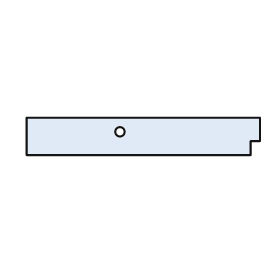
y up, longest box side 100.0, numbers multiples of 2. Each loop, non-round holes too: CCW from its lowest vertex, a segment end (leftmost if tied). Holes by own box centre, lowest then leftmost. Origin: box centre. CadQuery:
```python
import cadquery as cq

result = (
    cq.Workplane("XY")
    .moveTo(-50.0, -8.0)
    .lineTo(46.0, -8.0)
    .lineTo(46.0, -2.0)
    .lineTo(50.0, -2.0)
    .lineTo(50.0, 8.0)
    .lineTo(-50.0, 8.0)
    .close()
    .moveTo(-10.0, 2.0)
    .circle(2.0)
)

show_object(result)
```